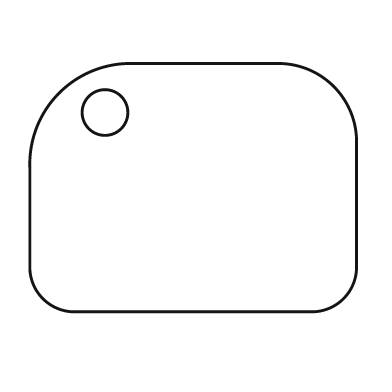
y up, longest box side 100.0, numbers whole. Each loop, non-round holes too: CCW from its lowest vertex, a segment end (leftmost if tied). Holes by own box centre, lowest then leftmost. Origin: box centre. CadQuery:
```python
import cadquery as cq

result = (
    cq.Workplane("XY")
    .moveTo(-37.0, -38.0)
    .lineTo(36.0, -38.0)
    .threePointArc((46.0, -34.0), (50.0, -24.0))
    .lineTo(50.0, 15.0)
    .threePointArc((43.0, 31.0), (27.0, 38.0))
    .lineTo(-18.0, 38.0)
    .threePointArc((-41.0, 29.0), (-50.0, 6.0))
    .lineTo(-50.0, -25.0)
    .threePointArc((-46.0, -34.0), (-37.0, -38.0))
    .close()
    .moveTo(-27.0, 23.0)
    .circle(7.0)
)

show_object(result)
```